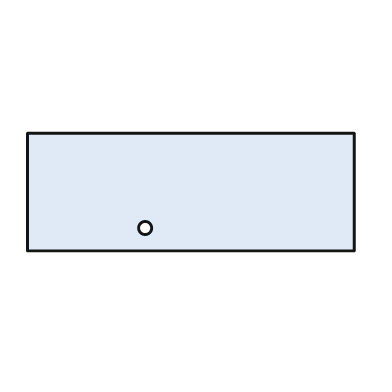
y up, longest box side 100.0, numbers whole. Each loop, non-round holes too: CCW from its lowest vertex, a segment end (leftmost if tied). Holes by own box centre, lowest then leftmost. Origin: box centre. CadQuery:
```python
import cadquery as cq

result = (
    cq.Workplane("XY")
    .moveTo(-50.0, -18.0)
    .lineTo(50.0, -18.0)
    .lineTo(50.0, 18.0)
    .lineTo(-50.0, 18.0)
    .close()
    .moveTo(-14.0, -11.0)
    .circle(2.0)
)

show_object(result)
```